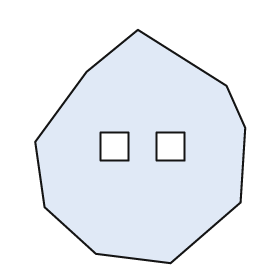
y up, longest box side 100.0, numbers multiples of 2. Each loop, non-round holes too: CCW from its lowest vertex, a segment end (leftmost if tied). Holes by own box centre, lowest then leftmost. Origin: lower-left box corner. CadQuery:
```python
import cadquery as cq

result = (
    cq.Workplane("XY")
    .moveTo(58.0, 0.0)
    .lineTo(88.0, 26.0)
    .lineTo(90.0, 58.0)
    .lineTo(82.0, 76.0)
    .lineTo(44.0, 100.0)
    .lineTo(22.0, 82.0)
    .lineTo(0.0, 52.0)
    .lineTo(4.0, 24.0)
    .lineTo(26.0, 4.0)
    .close()
    .moveTo(28.0, 44.0)
    .lineTo(40.0, 44.0)
    .lineTo(40.0, 56.0)
    .lineTo(28.0, 56.0)
    .close()
    .moveTo(52.0, 44.0)
    .lineTo(64.0, 44.0)
    .lineTo(64.0, 56.0)
    .lineTo(52.0, 56.0)
    .close()
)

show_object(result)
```